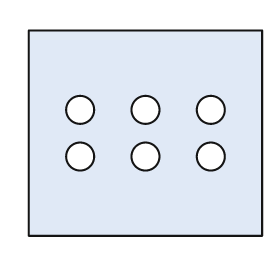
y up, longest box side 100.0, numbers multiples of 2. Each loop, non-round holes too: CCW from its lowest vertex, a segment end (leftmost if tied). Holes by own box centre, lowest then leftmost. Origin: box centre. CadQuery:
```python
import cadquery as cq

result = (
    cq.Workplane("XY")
    .moveTo(-50.0, -44.0)
    .lineTo(50.0, -44.0)
    .lineTo(50.0, 44.0)
    .lineTo(-50.0, 44.0)
    .close()
    .moveTo(-28.0, -10.0)
    .circle(6.0)
    .moveTo(0.0, -10.0)
    .circle(6.0)
    .moveTo(28.0, -10.0)
    .circle(6.0)
    .moveTo(-28.0, 10.0)
    .circle(6.0)
    .moveTo(0.0, 10.0)
    .circle(6.0)
    .moveTo(28.0, 10.0)
    .circle(6.0)
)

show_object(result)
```